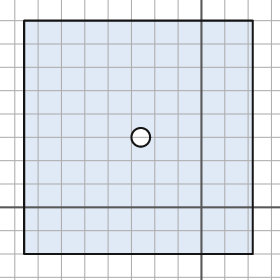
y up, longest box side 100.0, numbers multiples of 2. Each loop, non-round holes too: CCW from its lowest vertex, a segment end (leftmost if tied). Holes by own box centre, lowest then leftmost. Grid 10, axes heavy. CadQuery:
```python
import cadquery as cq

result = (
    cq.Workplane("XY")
    .moveTo(-76.0, -20.0)
    .lineTo(22.0, -20.0)
    .lineTo(22.0, 80.0)
    .lineTo(-76.0, 80.0)
    .close()
    .moveTo(-26.0, 30.0)
    .circle(4.0)
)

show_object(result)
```